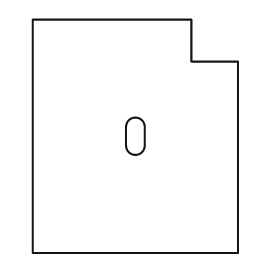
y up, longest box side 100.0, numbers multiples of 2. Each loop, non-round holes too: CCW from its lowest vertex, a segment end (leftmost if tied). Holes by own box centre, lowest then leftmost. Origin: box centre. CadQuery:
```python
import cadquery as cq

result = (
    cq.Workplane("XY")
    .moveTo(-44.0, -50.0)
    .lineTo(44.0, -50.0)
    .lineTo(44.0, 32.0)
    .lineTo(24.0, 32.0)
    .lineTo(24.0, 50.0)
    .lineTo(-44.0, 50.0)
    .close()
    .moveTo(-4.0, -4.0)
    .threePointArc((0.0, -8.0), (4.0, -4.0))
    .lineTo(4.0, 4.0)
    .threePointArc((0.0, 8.0), (-4.0, 4.0))
    .close()
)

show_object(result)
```